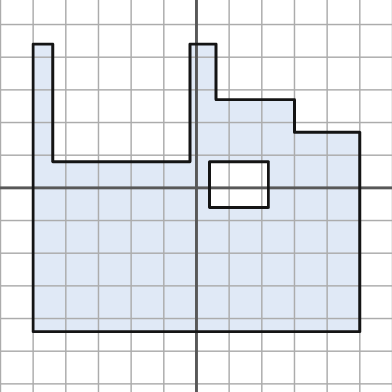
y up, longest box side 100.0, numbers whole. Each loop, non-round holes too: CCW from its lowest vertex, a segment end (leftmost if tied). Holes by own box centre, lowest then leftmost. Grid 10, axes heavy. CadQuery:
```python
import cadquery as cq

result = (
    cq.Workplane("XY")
    .moveTo(-50.0, -44.0)
    .lineTo(50.0, -44.0)
    .lineTo(50.0, 17.0)
    .lineTo(30.0, 17.0)
    .lineTo(30.0, 27.0)
    .lineTo(6.0, 27.0)
    .lineTo(6.0, 44.0)
    .lineTo(-2.0, 44.0)
    .lineTo(-2.0, 8.0)
    .lineTo(-44.0, 8.0)
    .lineTo(-44.0, 44.0)
    .lineTo(-50.0, 44.0)
    .close()
    .moveTo(4.0, -6.0)
    .lineTo(22.0, -6.0)
    .lineTo(22.0, 8.0)
    .lineTo(4.0, 8.0)
    .close()
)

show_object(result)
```